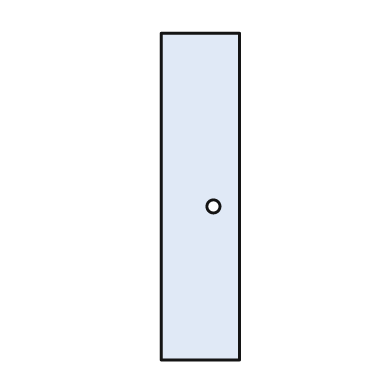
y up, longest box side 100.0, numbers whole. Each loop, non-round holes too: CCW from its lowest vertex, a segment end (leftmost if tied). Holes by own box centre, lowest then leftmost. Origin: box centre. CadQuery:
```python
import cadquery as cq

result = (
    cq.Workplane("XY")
    .moveTo(-12.0, -50.0)
    .lineTo(12.0, -50.0)
    .lineTo(12.0, 50.0)
    .lineTo(-12.0, 50.0)
    .close()
    .moveTo(4.0, -3.0)
    .circle(2.0)
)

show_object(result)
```